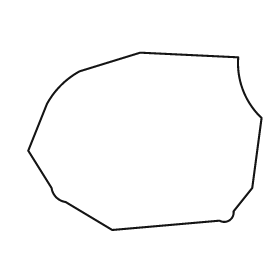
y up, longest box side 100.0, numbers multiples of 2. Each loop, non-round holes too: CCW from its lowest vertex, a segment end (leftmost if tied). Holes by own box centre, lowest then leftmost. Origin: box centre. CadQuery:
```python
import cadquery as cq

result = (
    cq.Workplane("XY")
    .moveTo(-14.0, -38.0)
    .lineTo(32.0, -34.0)
    .threePointArc((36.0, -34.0), (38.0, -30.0))
    .lineTo(46.0, -20.0)
    .lineTo(50.0, 10.0)
    .threePointArc((42.0, 22.0), (40.0, 36.0))
    .lineTo(-2.0, 38.0)
    .lineTo(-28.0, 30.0)
    .threePointArc((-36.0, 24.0), (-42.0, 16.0))
    .lineTo(-50.0, -4.0)
    .lineTo(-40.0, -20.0)
    .threePointArc((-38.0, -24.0), (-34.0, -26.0))
    .close()
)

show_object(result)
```